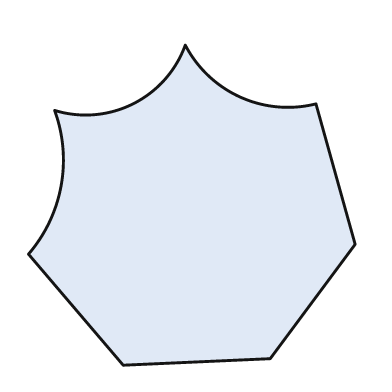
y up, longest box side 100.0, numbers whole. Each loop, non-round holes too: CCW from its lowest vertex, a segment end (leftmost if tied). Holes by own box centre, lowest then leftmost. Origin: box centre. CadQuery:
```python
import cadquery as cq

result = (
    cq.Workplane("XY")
    .moveTo(-21.0, -49.0)
    .lineTo(24.0, -47.0)
    .lineTo(50.0, -12.0)
    .lineTo(38.0, 31.0)
    .threePointArc((15.0, 33.0), (-2.0, 49.0))
    .threePointArc((-18.0, 31.0), (-42.0, 29.0))
    .threePointArc((-40.0, 6.0), (-50.0, -15.0))
    .close()
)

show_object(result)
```